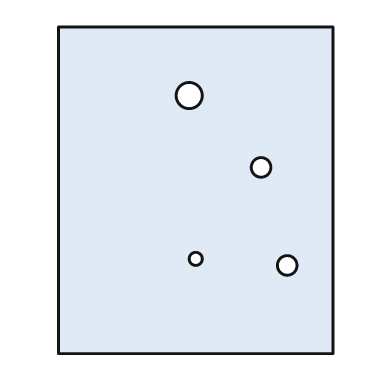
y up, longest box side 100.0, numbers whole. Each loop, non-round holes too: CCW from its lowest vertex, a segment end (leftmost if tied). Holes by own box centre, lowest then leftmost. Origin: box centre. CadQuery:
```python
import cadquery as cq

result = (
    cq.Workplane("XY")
    .moveTo(-42.0, -50.0)
    .lineTo(42.0, -50.0)
    .lineTo(42.0, 50.0)
    .lineTo(-42.0, 50.0)
    .close()
    .moveTo(28.0, -23.0)
    .circle(3.0)
    .moveTo(0.0, -21.0)
    .circle(2.0)
    .moveTo(20.0, 7.0)
    .circle(3.0)
    .moveTo(-2.0, 29.0)
    .circle(4.0)
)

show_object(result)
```